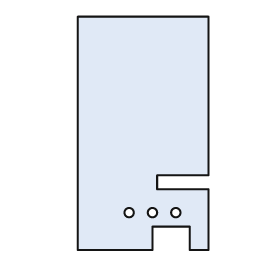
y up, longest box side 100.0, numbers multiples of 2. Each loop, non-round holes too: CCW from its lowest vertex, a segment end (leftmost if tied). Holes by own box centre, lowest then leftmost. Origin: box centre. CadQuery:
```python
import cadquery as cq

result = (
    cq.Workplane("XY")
    .moveTo(-28.0, -50.0)
    .lineTo(4.0, -50.0)
    .lineTo(4.0, -40.0)
    .lineTo(20.0, -40.0)
    .lineTo(20.0, -50.0)
    .lineTo(28.0, -50.0)
    .lineTo(28.0, -24.0)
    .lineTo(6.0, -24.0)
    .lineTo(6.0, -18.0)
    .lineTo(28.0, -18.0)
    .lineTo(28.0, 50.0)
    .lineTo(-28.0, 50.0)
    .close()
    .moveTo(-6.0, -34.0)
    .circle(2.0)
    .moveTo(4.0, -34.0)
    .circle(2.0)
    .moveTo(14.0, -34.0)
    .circle(2.0)
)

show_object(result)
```